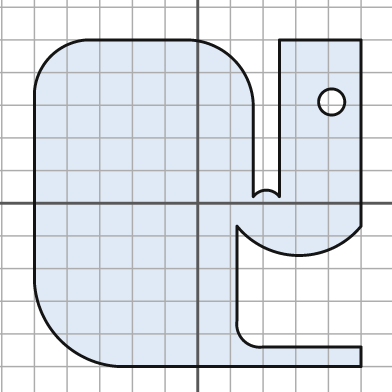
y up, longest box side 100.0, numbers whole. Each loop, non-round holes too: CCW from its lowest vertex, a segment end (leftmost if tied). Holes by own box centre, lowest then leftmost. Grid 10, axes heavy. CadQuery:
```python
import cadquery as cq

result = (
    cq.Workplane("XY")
    .moveTo(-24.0, -50.0)
    .lineTo(50.0, -50.0)
    .lineTo(50.0, -44.0)
    .lineTo(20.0, -44.0)
    .threePointArc((14.0, -42.0), (12.0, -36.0))
    .lineTo(12.0, -7.0)
    .threePointArc((31.0, -16.0), (50.0, -7.0))
    .lineTo(50.0, 50.0)
    .lineTo(25.0, 50.0)
    .lineTo(25.0, 2.0)
    .threePointArc((21.0, 4.0), (17.0, 2.0))
    .lineTo(17.0, 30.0)
    .threePointArc((11.0, 44.0), (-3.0, 50.0))
    .lineTo(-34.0, 50.0)
    .threePointArc((-45.0, 45.0), (-50.0, 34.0))
    .lineTo(-50.0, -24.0)
    .threePointArc((-42.0, -42.0), (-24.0, -50.0))
    .close()
    .moveTo(41.0, 31.0)
    .circle(4.0)
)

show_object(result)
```